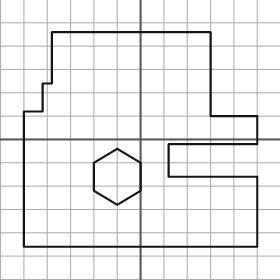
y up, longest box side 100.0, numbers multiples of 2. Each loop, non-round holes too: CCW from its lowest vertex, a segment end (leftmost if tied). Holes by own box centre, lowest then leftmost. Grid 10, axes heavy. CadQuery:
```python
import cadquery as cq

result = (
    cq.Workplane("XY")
    .moveTo(-50.0, -46.0)
    .lineTo(50.0, -46.0)
    .lineTo(50.0, -16.0)
    .lineTo(12.0, -16.0)
    .lineTo(12.0, -2.0)
    .lineTo(50.0, -2.0)
    .lineTo(50.0, 10.0)
    .lineTo(30.0, 10.0)
    .lineTo(30.0, 46.0)
    .lineTo(-38.0, 46.0)
    .lineTo(-38.0, 24.0)
    .lineTo(-42.0, 24.0)
    .lineTo(-42.0, 12.0)
    .lineTo(-50.0, 12.0)
    .close()
    .moveTo(-10.0, -28.0)
    .lineTo(0.0, -22.0)
    .lineTo(0.0, -10.0)
    .lineTo(-10.0, -4.0)
    .lineTo(-20.0, -10.0)
    .lineTo(-20.0, -22.0)
    .close()
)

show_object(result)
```